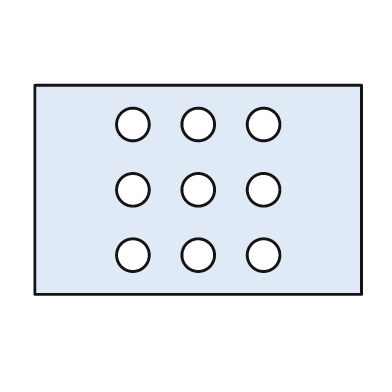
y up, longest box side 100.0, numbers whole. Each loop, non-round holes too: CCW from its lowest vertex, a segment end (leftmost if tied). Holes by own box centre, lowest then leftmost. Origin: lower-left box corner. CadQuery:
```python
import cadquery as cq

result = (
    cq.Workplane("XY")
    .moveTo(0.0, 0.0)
    .lineTo(100.0, 0.0)
    .lineTo(100.0, 64.0)
    .lineTo(0.0, 64.0)
    .close()
    .moveTo(30.0, 12.0)
    .circle(5.0)
    .moveTo(50.0, 12.0)
    .circle(5.0)
    .moveTo(70.0, 12.0)
    .circle(5.0)
    .moveTo(30.0, 32.0)
    .circle(5.0)
    .moveTo(50.0, 32.0)
    .circle(5.0)
    .moveTo(70.0, 32.0)
    .circle(5.0)
    .moveTo(30.0, 52.0)
    .circle(5.0)
    .moveTo(50.0, 52.0)
    .circle(5.0)
    .moveTo(70.0, 52.0)
    .circle(5.0)
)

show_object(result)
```